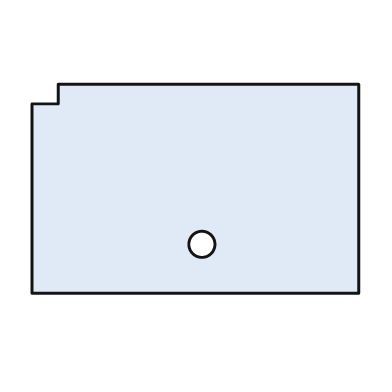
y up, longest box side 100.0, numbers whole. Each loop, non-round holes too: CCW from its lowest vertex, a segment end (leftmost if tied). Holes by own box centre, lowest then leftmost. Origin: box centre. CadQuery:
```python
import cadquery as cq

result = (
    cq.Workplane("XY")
    .moveTo(-50.0, -32.0)
    .lineTo(50.0, -32.0)
    .lineTo(50.0, 32.0)
    .lineTo(-42.0, 32.0)
    .lineTo(-42.0, 26.0)
    .lineTo(-50.0, 26.0)
    .close()
    .moveTo(2.0, -17.0)
    .circle(4.0)
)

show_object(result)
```